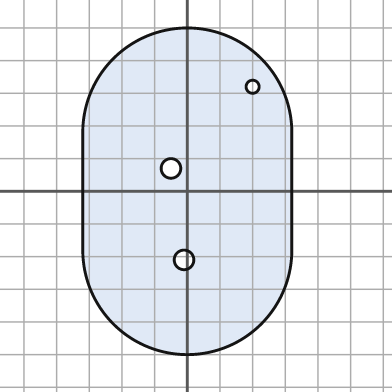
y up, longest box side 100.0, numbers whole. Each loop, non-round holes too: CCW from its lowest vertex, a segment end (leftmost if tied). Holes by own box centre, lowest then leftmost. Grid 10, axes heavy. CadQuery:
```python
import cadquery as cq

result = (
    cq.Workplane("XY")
    .moveTo(-32.0, -18.0)
    .threePointArc((0.0, -50.0), (32.0, -18.0))
    .lineTo(32.0, 18.0)
    .threePointArc((0.0, 50.0), (-32.0, 18.0))
    .close()
    .moveTo(-1.0, -21.0)
    .circle(3.0)
    .moveTo(-5.0, 7.0)
    .circle(3.0)
    .moveTo(20.0, 32.0)
    .circle(2.0)
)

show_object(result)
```